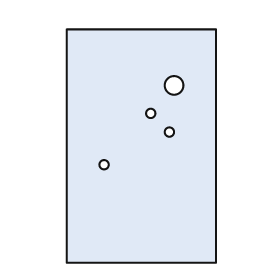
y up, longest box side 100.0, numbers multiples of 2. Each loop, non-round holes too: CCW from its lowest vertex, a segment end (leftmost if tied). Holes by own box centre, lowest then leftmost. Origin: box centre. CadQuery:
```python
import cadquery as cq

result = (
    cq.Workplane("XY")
    .moveTo(-32.0, -50.0)
    .lineTo(32.0, -50.0)
    .lineTo(32.0, 50.0)
    .lineTo(-32.0, 50.0)
    .close()
    .moveTo(-16.0, -8.0)
    .circle(2.0)
    .moveTo(12.0, 6.0)
    .circle(2.0)
    .moveTo(4.0, 14.0)
    .circle(2.0)
    .moveTo(14.0, 26.0)
    .circle(4.0)
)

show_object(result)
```